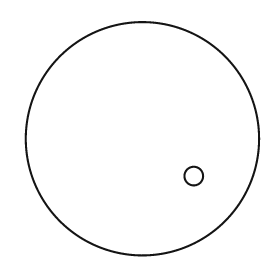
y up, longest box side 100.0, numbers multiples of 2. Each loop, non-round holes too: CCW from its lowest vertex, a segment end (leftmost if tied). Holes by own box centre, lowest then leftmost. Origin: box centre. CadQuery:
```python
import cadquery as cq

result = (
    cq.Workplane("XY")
    .moveTo(0.0, 0.0)
    .circle(50.0)
    .moveTo(22.0, -16.0)
    .circle(4.0)
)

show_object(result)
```